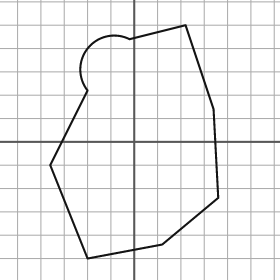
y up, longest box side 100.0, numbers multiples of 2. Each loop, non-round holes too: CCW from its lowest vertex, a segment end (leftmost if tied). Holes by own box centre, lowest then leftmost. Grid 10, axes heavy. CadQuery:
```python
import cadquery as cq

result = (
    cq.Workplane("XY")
    .moveTo(-20.0, -50.0)
    .lineTo(12.0, -44.0)
    .lineTo(36.0, -24.0)
    .lineTo(34.0, 14.0)
    .lineTo(22.0, 50.0)
    .lineTo(-2.0, 44.0)
    .threePointArc((-20.0, 40.0), (-20.0, 22.0))
    .lineTo(-36.0, -10.0)
    .close()
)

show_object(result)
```